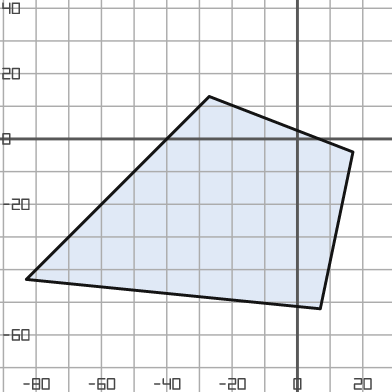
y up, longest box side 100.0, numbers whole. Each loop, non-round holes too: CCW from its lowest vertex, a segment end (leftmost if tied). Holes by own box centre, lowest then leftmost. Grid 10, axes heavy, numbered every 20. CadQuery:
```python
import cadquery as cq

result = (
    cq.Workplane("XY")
    .moveTo(7.0, -52.0)
    .lineTo(17.0, -4.0)
    .lineTo(-27.0, 13.0)
    .lineTo(-83.0, -43.0)
    .close()
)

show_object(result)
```